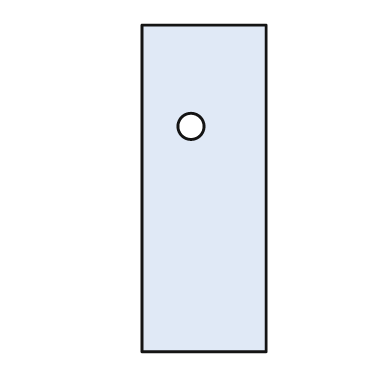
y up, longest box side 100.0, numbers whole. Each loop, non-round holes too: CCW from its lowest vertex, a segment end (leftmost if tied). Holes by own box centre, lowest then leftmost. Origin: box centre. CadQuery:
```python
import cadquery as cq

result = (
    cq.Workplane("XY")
    .moveTo(-19.0, -50.0)
    .lineTo(19.0, -50.0)
    .lineTo(19.0, 50.0)
    .lineTo(-19.0, 50.0)
    .close()
    .moveTo(-4.0, 19.0)
    .circle(4.0)
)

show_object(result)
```